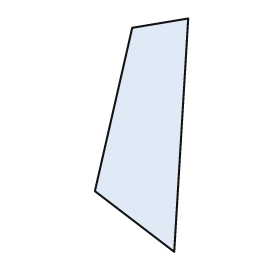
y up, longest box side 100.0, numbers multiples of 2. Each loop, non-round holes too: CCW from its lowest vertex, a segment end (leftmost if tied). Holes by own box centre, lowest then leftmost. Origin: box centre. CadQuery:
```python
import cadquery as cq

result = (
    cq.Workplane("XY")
    .moveTo(14.0, -50.0)
    .lineTo(20.0, 50.0)
    .lineTo(-4.0, 46.0)
    .lineTo(-20.0, -24.0)
    .close()
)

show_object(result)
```